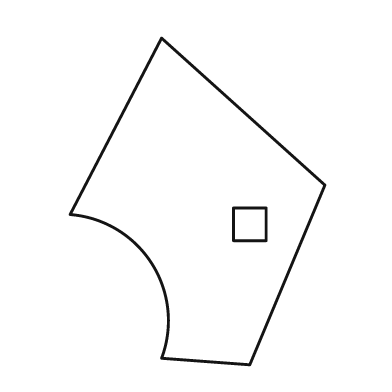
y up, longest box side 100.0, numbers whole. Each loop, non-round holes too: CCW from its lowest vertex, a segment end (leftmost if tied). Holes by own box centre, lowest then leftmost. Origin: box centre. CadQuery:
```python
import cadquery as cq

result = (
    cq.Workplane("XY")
    .moveTo(16.0, -50.0)
    .lineTo(39.0, 5.0)
    .lineTo(-11.0, 50.0)
    .lineTo(-39.0, -4.0)
    .threePointArc((-14.0, -19.0), (-11.0, -48.0))
    .close()
    .moveTo(11.0, -12.0)
    .lineTo(21.0, -12.0)
    .lineTo(21.0, -2.0)
    .lineTo(11.0, -2.0)
    .close()
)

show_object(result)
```